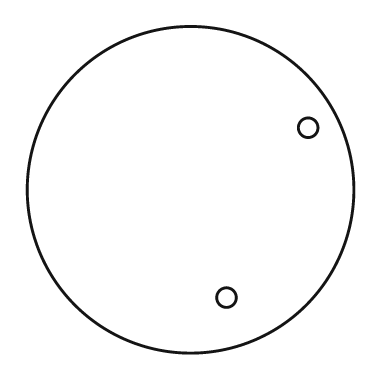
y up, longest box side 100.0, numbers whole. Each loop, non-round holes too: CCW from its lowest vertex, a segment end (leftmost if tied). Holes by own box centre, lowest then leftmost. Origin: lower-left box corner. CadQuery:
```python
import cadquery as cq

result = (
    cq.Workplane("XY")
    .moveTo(50.0, 50.0)
    .circle(50.0)
    .moveTo(61.0, 17.0)
    .circle(3.0)
    .moveTo(86.0, 69.0)
    .circle(3.0)
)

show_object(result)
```